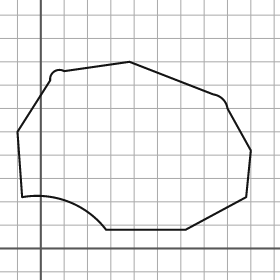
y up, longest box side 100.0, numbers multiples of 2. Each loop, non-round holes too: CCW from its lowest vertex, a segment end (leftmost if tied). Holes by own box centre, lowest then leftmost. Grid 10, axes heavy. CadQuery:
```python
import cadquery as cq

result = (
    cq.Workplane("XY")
    .moveTo(28.0, 8.0)
    .lineTo(62.0, 8.0)
    .lineTo(88.0, 22.0)
    .lineTo(90.0, 42.0)
    .lineTo(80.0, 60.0)
    .threePointArc((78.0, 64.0), (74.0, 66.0))
    .lineTo(38.0, 80.0)
    .lineTo(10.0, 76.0)
    .threePointArc((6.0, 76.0), (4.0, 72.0))
    .lineTo(-10.0, 50.0)
    .lineTo(-8.0, 22.0)
    .threePointArc((12.0, 20.0), (28.0, 8.0))
    .close()
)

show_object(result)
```